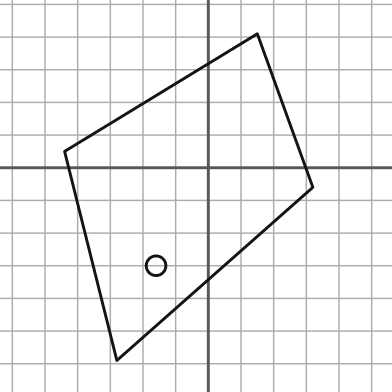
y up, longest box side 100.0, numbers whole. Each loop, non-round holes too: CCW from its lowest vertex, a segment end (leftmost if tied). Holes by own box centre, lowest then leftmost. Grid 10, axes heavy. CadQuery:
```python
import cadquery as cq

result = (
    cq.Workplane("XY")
    .moveTo(-28.0, -59.0)
    .lineTo(32.0, -6.0)
    .lineTo(15.0, 41.0)
    .lineTo(-44.0, 5.0)
    .close()
    .moveTo(-16.0, -30.0)
    .circle(3.0)
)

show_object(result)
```